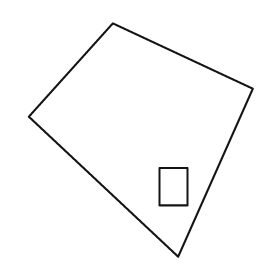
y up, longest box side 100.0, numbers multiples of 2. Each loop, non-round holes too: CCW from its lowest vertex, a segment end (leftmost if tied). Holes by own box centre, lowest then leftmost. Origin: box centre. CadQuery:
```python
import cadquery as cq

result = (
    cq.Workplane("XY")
    .moveTo(16.0, -50.0)
    .lineTo(48.0, 22.0)
    .lineTo(-12.0, 50.0)
    .lineTo(-48.0, 10.0)
    .close()
    .moveTo(8.0, -28.0)
    .lineTo(20.0, -28.0)
    .lineTo(20.0, -12.0)
    .lineTo(8.0, -12.0)
    .close()
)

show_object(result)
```